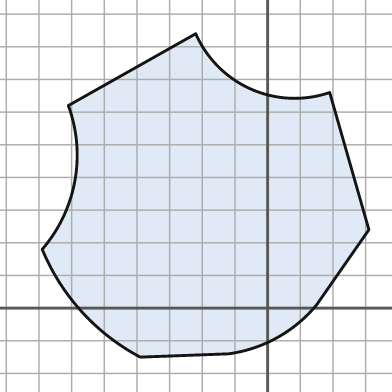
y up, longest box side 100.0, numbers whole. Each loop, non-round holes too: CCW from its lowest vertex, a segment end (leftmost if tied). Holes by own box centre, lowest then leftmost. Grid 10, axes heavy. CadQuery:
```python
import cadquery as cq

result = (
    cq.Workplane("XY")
    .moveTo(-39.0, -15.0)
    .lineTo(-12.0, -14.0)
    .threePointArc((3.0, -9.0), (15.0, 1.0))
    .lineTo(31.0, 24.0)
    .lineTo(19.0, 66.0)
    .threePointArc((-5.0, 67.0), (-22.0, 84.0))
    .lineTo(-61.0, 62.0)
    .threePointArc((-59.0, 39.0), (-69.0, 18.0))
    .threePointArc((-57.0, -1.0), (-39.0, -15.0))
    .close()
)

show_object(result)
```